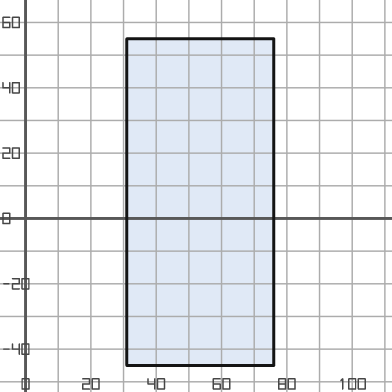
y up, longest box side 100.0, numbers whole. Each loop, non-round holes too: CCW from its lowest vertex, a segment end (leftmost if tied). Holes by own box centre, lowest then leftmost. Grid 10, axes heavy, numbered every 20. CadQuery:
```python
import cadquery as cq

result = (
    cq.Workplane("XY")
    .moveTo(31.0, -45.0)
    .lineTo(76.0, -45.0)
    .lineTo(76.0, 55.0)
    .lineTo(31.0, 55.0)
    .close()
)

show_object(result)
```